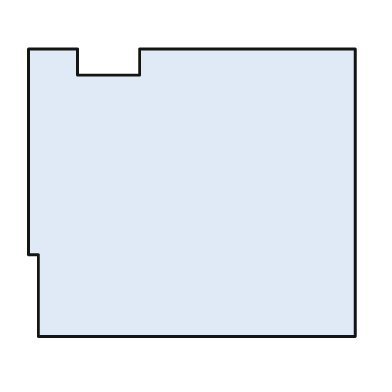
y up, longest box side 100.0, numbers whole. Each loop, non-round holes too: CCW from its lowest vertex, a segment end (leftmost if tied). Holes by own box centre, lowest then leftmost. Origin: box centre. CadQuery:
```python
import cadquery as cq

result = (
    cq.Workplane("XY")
    .moveTo(-47.0, -44.0)
    .lineTo(50.0, -44.0)
    .lineTo(50.0, 44.0)
    .lineTo(-16.0, 44.0)
    .lineTo(-16.0, 36.0)
    .lineTo(-35.0, 36.0)
    .lineTo(-35.0, 44.0)
    .lineTo(-50.0, 44.0)
    .lineTo(-50.0, -19.0)
    .lineTo(-47.0, -19.0)
    .close()
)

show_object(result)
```